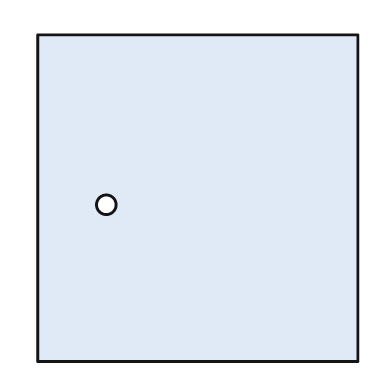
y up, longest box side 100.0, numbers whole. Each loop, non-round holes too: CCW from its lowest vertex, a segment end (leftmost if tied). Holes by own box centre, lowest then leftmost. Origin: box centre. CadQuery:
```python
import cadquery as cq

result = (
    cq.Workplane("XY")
    .moveTo(-49.0, -50.0)
    .lineTo(49.0, -50.0)
    .lineTo(49.0, 50.0)
    .lineTo(-49.0, 50.0)
    .close()
    .moveTo(-28.0, -2.0)
    .circle(3.0)
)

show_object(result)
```